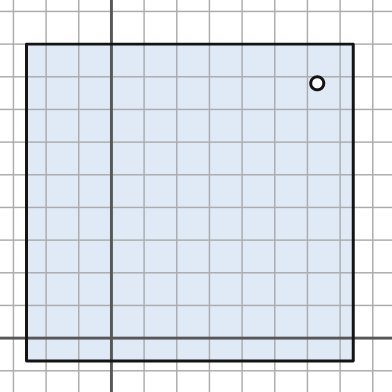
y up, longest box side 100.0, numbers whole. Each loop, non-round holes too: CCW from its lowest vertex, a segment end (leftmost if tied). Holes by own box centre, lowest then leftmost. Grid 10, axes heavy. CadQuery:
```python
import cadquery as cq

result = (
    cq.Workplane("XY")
    .moveTo(-26.0, -7.0)
    .lineTo(74.0, -7.0)
    .lineTo(74.0, 90.0)
    .lineTo(-26.0, 90.0)
    .close()
    .moveTo(63.0, 78.0)
    .circle(2.0)
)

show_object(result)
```